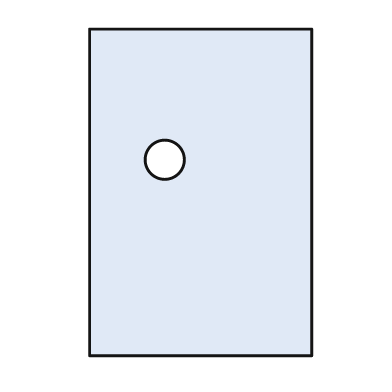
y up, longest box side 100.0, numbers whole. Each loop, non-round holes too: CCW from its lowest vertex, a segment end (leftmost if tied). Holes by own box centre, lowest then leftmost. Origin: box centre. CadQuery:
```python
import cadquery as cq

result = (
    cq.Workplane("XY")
    .moveTo(-34.0, -50.0)
    .lineTo(34.0, -50.0)
    .lineTo(34.0, 50.0)
    .lineTo(-34.0, 50.0)
    .close()
    .moveTo(-11.0, 10.0)
    .circle(6.0)
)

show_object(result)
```